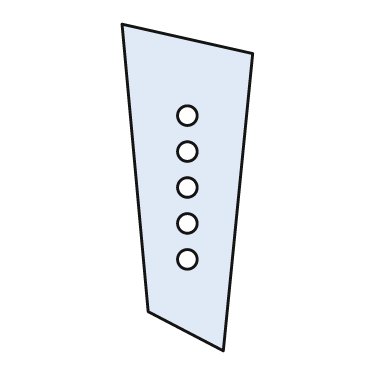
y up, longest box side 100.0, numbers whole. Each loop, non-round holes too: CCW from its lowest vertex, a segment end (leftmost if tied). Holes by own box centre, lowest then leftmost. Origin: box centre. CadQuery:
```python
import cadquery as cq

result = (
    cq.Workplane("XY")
    .moveTo(11.0, -50.0)
    .lineTo(20.0, 41.0)
    .lineTo(-20.0, 50.0)
    .lineTo(-12.0, -38.0)
    .close()
    .moveTo(0.0, -22.0)
    .circle(3.0)
    .moveTo(0.0, -11.0)
    .circle(3.0)
    .moveTo(0.0, 0.0)
    .circle(3.0)
    .moveTo(0.0, 11.0)
    .circle(3.0)
    .moveTo(0.0, 22.0)
    .circle(3.0)
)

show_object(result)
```